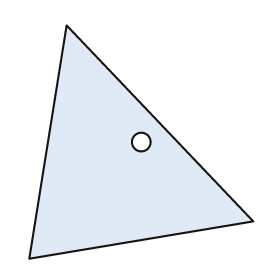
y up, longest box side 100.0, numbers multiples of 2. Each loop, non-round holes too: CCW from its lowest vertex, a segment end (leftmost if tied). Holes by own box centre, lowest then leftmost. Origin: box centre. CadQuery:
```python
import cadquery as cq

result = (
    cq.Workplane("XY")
    .moveTo(-48.0, -50.0)
    .lineTo(48.0, -34.0)
    .lineTo(-32.0, 50.0)
    .close()
    .moveTo(0.0, 0.0)
    .circle(4.0)
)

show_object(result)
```